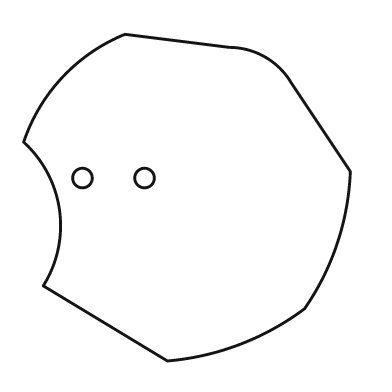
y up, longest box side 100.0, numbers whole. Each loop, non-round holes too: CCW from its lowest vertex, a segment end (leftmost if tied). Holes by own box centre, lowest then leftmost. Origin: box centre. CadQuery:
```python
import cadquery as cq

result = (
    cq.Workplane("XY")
    .moveTo(-6.0, -50.0)
    .threePointArc((16.0, -45.0), (36.0, -34.0))
    .threePointArc((46.0, -14.0), (50.0, 8.0))
    .lineTo(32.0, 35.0)
    .threePointArc((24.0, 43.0), (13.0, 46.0))
    .lineTo(-19.0, 50.0)
    .threePointArc((-38.0, 37.0), (-50.0, 17.0))
    .threePointArc((-39.0, -4.0), (-44.0, -27.0))
    .close()
    .moveTo(-32.0, 6.0)
    .circle(3.0)
    .moveTo(-13.0, 6.0)
    .circle(3.0)
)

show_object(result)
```